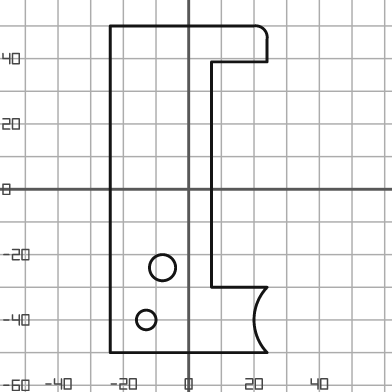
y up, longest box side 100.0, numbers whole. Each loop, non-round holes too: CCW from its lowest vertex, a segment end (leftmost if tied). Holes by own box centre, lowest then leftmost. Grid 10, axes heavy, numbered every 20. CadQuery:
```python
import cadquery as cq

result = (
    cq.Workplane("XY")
    .moveTo(-24.0, -50.0)
    .lineTo(24.0, -50.0)
    .threePointArc((20.0, -40.0), (24.0, -30.0))
    .lineTo(7.0, -30.0)
    .lineTo(7.0, 39.0)
    .lineTo(24.0, 39.0)
    .lineTo(24.0, 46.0)
    .threePointArc((23.0, 49.0), (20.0, 50.0))
    .lineTo(-24.0, 50.0)
    .close()
    .moveTo(-13.0, -40.0)
    .circle(3.0)
    .moveTo(-8.0, -24.0)
    .circle(4.0)
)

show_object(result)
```